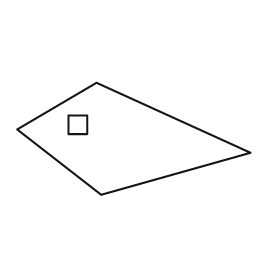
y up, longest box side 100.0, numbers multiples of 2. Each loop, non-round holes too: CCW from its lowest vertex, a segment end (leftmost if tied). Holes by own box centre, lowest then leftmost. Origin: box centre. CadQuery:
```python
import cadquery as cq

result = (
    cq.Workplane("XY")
    .moveTo(-14.0, -24.0)
    .lineTo(50.0, -6.0)
    .lineTo(-16.0, 24.0)
    .lineTo(-50.0, 4.0)
    .close()
    .moveTo(-28.0, 2.0)
    .lineTo(-20.0, 2.0)
    .lineTo(-20.0, 10.0)
    .lineTo(-28.0, 10.0)
    .close()
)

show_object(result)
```